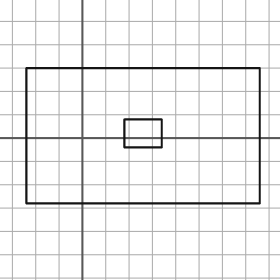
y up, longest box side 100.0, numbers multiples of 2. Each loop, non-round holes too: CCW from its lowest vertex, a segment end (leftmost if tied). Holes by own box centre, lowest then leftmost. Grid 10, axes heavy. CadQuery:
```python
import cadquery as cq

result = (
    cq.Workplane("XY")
    .moveTo(-24.0, -28.0)
    .lineTo(76.0, -28.0)
    .lineTo(76.0, 30.0)
    .lineTo(-24.0, 30.0)
    .close()
    .moveTo(18.0, -4.0)
    .lineTo(34.0, -4.0)
    .lineTo(34.0, 8.0)
    .lineTo(18.0, 8.0)
    .close()
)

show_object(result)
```